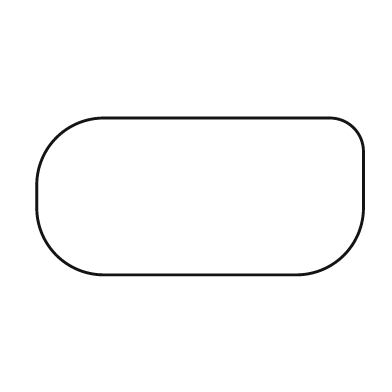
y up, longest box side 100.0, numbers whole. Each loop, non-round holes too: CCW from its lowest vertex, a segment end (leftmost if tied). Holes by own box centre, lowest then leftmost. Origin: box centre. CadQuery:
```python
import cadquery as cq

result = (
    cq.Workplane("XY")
    .moveTo(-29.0, -24.0)
    .lineTo(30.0, -24.0)
    .threePointArc((44.0, -18.0), (50.0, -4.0))
    .lineTo(50.0, 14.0)
    .threePointArc((47.0, 21.0), (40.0, 24.0))
    .lineTo(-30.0, 24.0)
    .threePointArc((-44.0, 18.0), (-50.0, 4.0))
    .lineTo(-50.0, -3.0)
    .threePointArc((-44.0, -18.0), (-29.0, -24.0))
    .close()
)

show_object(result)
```